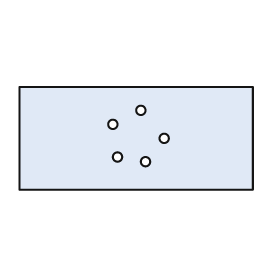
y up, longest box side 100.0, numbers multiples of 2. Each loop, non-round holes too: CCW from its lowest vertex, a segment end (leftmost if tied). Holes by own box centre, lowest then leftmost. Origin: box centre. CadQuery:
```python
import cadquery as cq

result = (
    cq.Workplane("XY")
    .moveTo(-50.0, -22.0)
    .lineTo(50.0, -22.0)
    .lineTo(50.0, 22.0)
    .lineTo(-50.0, 22.0)
    .close()
    .moveTo(4.0, -10.0)
    .circle(2.0)
    .moveTo(-8.0, -8.0)
    .circle(2.0)
    .moveTo(12.0, 0.0)
    .circle(2.0)
    .moveTo(-10.0, 6.0)
    .circle(2.0)
    .moveTo(2.0, 12.0)
    .circle(2.0)
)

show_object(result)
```